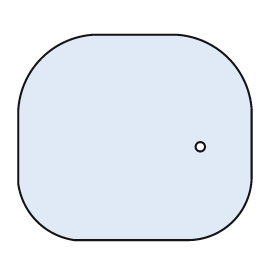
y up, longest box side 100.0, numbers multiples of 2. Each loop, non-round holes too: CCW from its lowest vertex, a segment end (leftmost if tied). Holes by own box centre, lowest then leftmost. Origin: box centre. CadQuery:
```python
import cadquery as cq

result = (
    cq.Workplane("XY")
    .moveTo(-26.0, -44.0)
    .lineTo(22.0, -44.0)
    .threePointArc((42.0, -36.0), (50.0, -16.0))
    .lineTo(50.0, 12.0)
    .threePointArc((40.0, 34.0), (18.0, 44.0))
    .lineTo(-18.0, 44.0)
    .threePointArc((-40.0, 34.0), (-50.0, 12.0))
    .lineTo(-50.0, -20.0)
    .threePointArc((-42.0, -36.0), (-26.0, -44.0))
    .close()
    .moveTo(28.0, -4.0)
    .circle(2.0)
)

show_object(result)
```